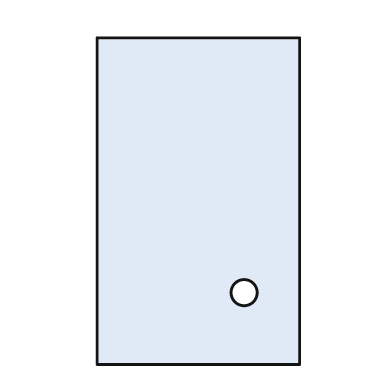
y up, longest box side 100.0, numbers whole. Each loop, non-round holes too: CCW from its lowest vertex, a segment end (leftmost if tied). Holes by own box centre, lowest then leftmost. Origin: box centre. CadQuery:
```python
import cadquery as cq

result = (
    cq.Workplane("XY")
    .moveTo(-31.0, -50.0)
    .lineTo(31.0, -50.0)
    .lineTo(31.0, 50.0)
    .lineTo(-31.0, 50.0)
    .close()
    .moveTo(14.0, -28.0)
    .circle(4.0)
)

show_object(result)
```